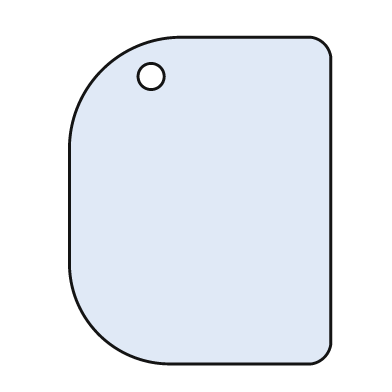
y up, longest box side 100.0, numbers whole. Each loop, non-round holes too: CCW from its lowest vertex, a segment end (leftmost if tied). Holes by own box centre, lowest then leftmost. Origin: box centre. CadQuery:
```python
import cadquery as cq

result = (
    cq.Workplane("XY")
    .moveTo(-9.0, -50.0)
    .lineTo(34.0, -50.0)
    .threePointArc((38.0, -48.0), (40.0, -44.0))
    .lineTo(40.0, 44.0)
    .threePointArc((38.0, 48.0), (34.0, 50.0))
    .lineTo(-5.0, 50.0)
    .threePointArc((-30.0, 40.0), (-40.0, 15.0))
    .lineTo(-40.0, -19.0)
    .threePointArc((-31.0, -41.0), (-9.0, -50.0))
    .close()
    .moveTo(-15.0, 38.0)
    .circle(4.0)
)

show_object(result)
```